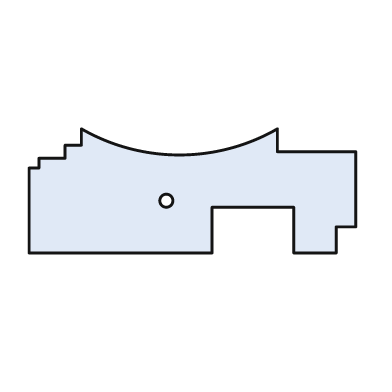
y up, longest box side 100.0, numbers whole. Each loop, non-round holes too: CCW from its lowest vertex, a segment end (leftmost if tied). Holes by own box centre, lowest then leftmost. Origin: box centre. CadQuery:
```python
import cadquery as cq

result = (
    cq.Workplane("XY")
    .moveTo(-50.0, -19.0)
    .lineTo(6.0, -19.0)
    .lineTo(6.0, -5.0)
    .lineTo(31.0, -5.0)
    .lineTo(31.0, -19.0)
    .lineTo(44.0, -19.0)
    .lineTo(44.0, -11.0)
    .lineTo(50.0, -11.0)
    .lineTo(50.0, 12.0)
    .lineTo(26.0, 12.0)
    .lineTo(26.0, 19.0)
    .threePointArc((-4.0, 11.0), (-34.0, 19.0))
    .lineTo(-34.0, 14.0)
    .lineTo(-39.0, 14.0)
    .lineTo(-39.0, 10.0)
    .lineTo(-47.0, 10.0)
    .lineTo(-47.0, 7.0)
    .lineTo(-50.0, 7.0)
    .close()
    .moveTo(-8.0, -3.0)
    .circle(2.0)
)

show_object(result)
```